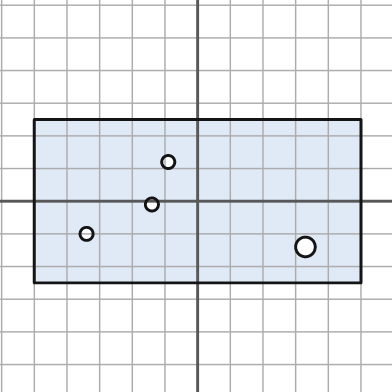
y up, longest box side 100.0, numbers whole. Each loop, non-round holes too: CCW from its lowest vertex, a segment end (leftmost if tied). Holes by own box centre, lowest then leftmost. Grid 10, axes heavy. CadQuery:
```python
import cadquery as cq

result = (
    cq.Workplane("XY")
    .moveTo(-50.0, -25.0)
    .lineTo(50.0, -25.0)
    .lineTo(50.0, 25.0)
    .lineTo(-50.0, 25.0)
    .close()
    .moveTo(33.0, -14.0)
    .circle(3.0)
    .moveTo(-34.0, -10.0)
    .circle(2.0)
    .moveTo(-14.0, -1.0)
    .circle(2.0)
    .moveTo(-9.0, 12.0)
    .circle(2.0)
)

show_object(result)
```